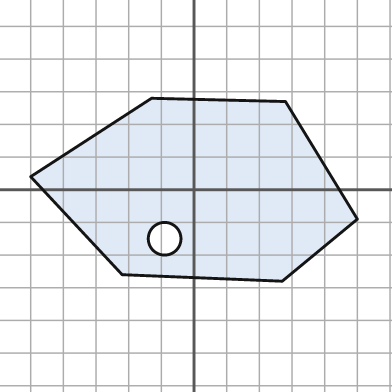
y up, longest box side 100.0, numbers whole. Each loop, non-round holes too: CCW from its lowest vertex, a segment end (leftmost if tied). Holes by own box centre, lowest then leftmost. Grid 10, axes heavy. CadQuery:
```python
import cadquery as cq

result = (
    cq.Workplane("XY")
    .moveTo(27.0, -28.0)
    .lineTo(50.0, -9.0)
    .lineTo(28.0, 27.0)
    .lineTo(-13.0, 28.0)
    .lineTo(-50.0, 4.0)
    .lineTo(-22.0, -26.0)
    .close()
    .moveTo(-9.0, -15.0)
    .circle(5.0)
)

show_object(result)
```